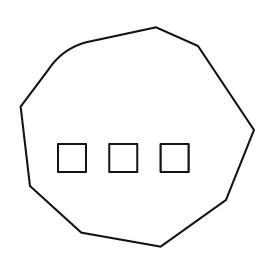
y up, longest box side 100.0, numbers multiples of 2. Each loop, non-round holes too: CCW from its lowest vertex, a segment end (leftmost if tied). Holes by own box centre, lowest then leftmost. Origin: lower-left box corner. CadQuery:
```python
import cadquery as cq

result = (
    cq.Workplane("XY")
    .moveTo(60.0, 0.0)
    .lineTo(88.0, 20.0)
    .lineTo(100.0, 50.0)
    .lineTo(76.0, 86.0)
    .lineTo(58.0, 94.0)
    .lineTo(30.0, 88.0)
    .threePointArc((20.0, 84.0), (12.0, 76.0))
    .lineTo(0.0, 60.0)
    .lineTo(4.0, 26.0)
    .lineTo(26.0, 6.0)
    .close()
    .moveTo(16.0, 32.0)
    .lineTo(28.0, 32.0)
    .lineTo(28.0, 44.0)
    .lineTo(16.0, 44.0)
    .close()
    .moveTo(38.0, 32.0)
    .lineTo(50.0, 32.0)
    .lineTo(50.0, 44.0)
    .lineTo(38.0, 44.0)
    .close()
    .moveTo(60.0, 32.0)
    .lineTo(72.0, 32.0)
    .lineTo(72.0, 44.0)
    .lineTo(60.0, 44.0)
    .close()
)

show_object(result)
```